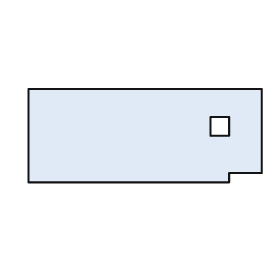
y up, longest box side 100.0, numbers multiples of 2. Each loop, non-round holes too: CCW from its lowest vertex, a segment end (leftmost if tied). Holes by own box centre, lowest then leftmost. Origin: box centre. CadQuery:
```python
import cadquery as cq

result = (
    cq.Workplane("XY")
    .moveTo(-50.0, -20.0)
    .lineTo(36.0, -20.0)
    .lineTo(36.0, -16.0)
    .lineTo(50.0, -16.0)
    .lineTo(50.0, 20.0)
    .lineTo(-50.0, 20.0)
    .close()
    .moveTo(28.0, 0.0)
    .lineTo(36.0, 0.0)
    .lineTo(36.0, 8.0)
    .lineTo(28.0, 8.0)
    .close()
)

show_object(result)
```